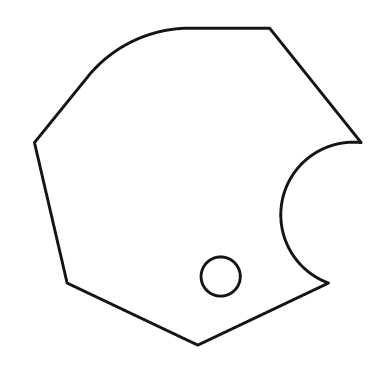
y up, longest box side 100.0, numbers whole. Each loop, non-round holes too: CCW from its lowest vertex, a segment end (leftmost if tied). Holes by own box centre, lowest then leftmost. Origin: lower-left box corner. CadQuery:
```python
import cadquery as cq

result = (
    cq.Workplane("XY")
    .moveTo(50.0, 0.0)
    .lineTo(90.0, 19.0)
    .threePointArc((76.0, 45.0), (100.0, 62.0))
    .lineTo(72.0, 97.0)
    .lineTo(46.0, 97.0)
    .threePointArc((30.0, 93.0), (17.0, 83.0))
    .lineTo(0.0, 62.0)
    .lineTo(10.0, 19.0)
    .close()
    .moveTo(57.0, 21.0)
    .circle(6.0)
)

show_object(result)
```